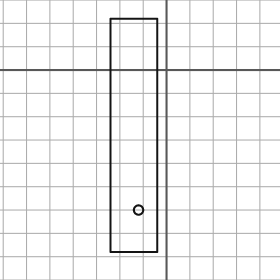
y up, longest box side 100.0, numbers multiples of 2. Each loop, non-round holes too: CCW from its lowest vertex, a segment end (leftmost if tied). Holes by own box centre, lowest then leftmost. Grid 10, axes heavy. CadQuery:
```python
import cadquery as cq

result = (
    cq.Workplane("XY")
    .moveTo(-24.0, -78.0)
    .lineTo(-4.0, -78.0)
    .lineTo(-4.0, 22.0)
    .lineTo(-24.0, 22.0)
    .close()
    .moveTo(-12.0, -60.0)
    .circle(2.0)
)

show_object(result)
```